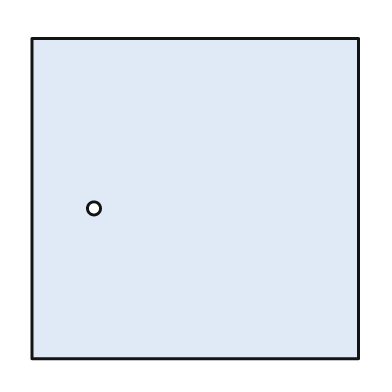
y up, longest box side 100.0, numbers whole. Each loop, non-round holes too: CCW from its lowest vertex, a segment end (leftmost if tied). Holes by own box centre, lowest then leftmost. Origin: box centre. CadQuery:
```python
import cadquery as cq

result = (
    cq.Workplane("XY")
    .moveTo(-50.0, -49.0)
    .lineTo(50.0, -49.0)
    .lineTo(50.0, 49.0)
    .lineTo(-50.0, 49.0)
    .close()
    .moveTo(-31.0, -3.0)
    .circle(2.0)
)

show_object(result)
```